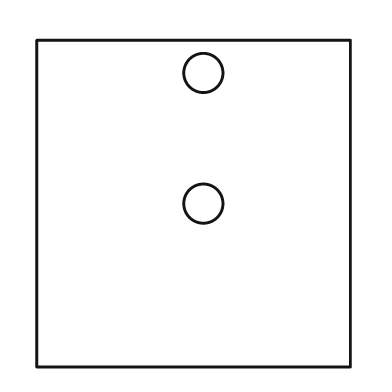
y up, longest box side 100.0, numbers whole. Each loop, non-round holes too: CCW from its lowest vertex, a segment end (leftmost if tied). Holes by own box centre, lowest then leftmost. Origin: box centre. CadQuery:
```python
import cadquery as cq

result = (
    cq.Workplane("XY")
    .moveTo(-48.0, -50.0)
    .lineTo(48.0, -50.0)
    .lineTo(48.0, 50.0)
    .lineTo(-48.0, 50.0)
    .close()
    .moveTo(3.0, 0.0)
    .circle(6.0)
    .moveTo(3.0, 40.0)
    .circle(6.0)
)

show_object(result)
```